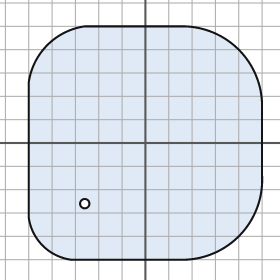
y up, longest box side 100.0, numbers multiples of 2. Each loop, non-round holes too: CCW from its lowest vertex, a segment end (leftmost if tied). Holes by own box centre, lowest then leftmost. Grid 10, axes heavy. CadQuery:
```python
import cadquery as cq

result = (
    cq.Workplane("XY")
    .moveTo(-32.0, -50.0)
    .lineTo(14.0, -50.0)
    .threePointArc((40.0, -40.0), (50.0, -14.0))
    .lineTo(50.0, 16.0)
    .threePointArc((40.0, 40.0), (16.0, 50.0))
    .lineTo(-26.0, 50.0)
    .threePointArc((-42.0, 42.0), (-50.0, 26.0))
    .lineTo(-50.0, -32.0)
    .threePointArc((-44.0, -44.0), (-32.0, -50.0))
    .close()
    .moveTo(-26.0, -26.0)
    .circle(2.0)
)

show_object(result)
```